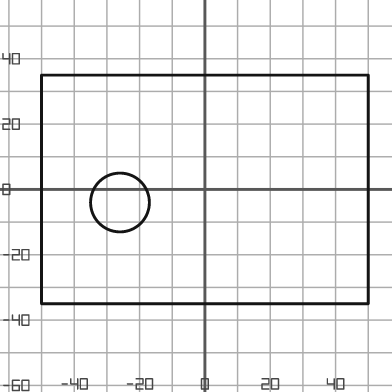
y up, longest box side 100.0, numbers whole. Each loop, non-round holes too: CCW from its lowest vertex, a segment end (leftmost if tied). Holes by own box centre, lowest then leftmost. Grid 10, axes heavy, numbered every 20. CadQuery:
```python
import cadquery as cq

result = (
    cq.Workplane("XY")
    .moveTo(-50.0, -35.0)
    .lineTo(50.0, -35.0)
    .lineTo(50.0, 35.0)
    .lineTo(-50.0, 35.0)
    .close()
    .moveTo(-26.0, -4.0)
    .circle(9.0)
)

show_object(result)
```